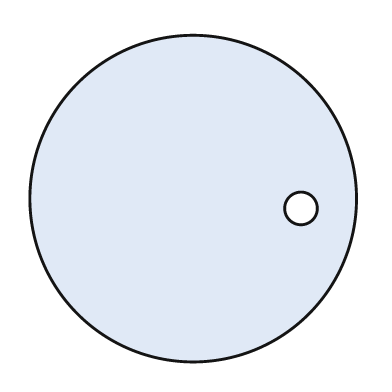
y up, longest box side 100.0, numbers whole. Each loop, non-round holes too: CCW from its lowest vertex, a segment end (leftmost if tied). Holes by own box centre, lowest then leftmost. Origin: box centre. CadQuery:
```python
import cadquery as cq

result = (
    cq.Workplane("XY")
    .moveTo(0.0, 0.0)
    .circle(50.0)
    .moveTo(33.0, -3.0)
    .circle(5.0)
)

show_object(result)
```